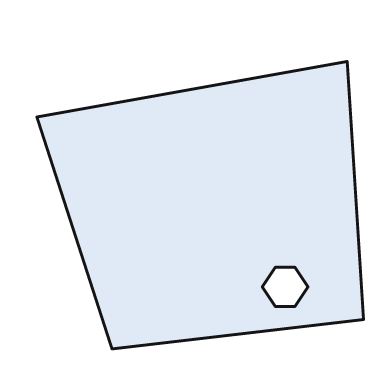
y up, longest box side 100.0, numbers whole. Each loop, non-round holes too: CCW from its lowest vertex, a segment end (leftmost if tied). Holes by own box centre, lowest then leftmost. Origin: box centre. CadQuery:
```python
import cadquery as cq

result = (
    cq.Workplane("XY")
    .moveTo(-27.0, -44.0)
    .lineTo(50.0, -35.0)
    .lineTo(45.0, 44.0)
    .lineTo(-50.0, 27.0)
    .close()
    .moveTo(23.0, -31.0)
    .lineTo(29.0, -31.0)
    .lineTo(33.0, -25.0)
    .lineTo(29.0, -19.0)
    .lineTo(23.0, -19.0)
    .lineTo(19.0, -25.0)
    .close()
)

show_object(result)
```